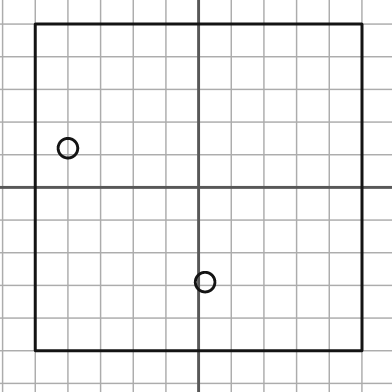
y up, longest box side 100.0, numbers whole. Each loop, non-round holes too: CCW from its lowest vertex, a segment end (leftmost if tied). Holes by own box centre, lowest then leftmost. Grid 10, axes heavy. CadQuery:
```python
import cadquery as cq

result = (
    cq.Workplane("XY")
    .moveTo(-50.0, -50.0)
    .lineTo(50.0, -50.0)
    .lineTo(50.0, 50.0)
    .lineTo(-50.0, 50.0)
    .close()
    .moveTo(2.0, -29.0)
    .circle(3.0)
    .moveTo(-40.0, 12.0)
    .circle(3.0)
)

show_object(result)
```